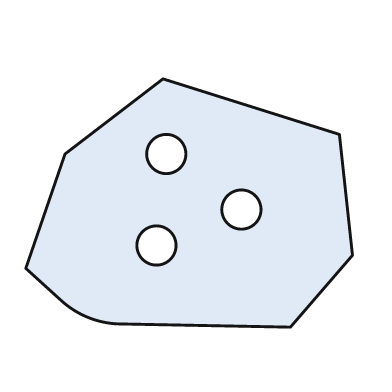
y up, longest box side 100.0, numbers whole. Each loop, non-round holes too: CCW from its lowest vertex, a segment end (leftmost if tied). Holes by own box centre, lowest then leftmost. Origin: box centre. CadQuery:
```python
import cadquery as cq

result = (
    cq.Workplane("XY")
    .moveTo(31.0, -38.0)
    .lineTo(50.0, -16.0)
    .lineTo(46.0, 21.0)
    .lineTo(-8.0, 38.0)
    .lineTo(-38.0, 15.0)
    .lineTo(-50.0, -20.0)
    .lineTo(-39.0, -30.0)
    .threePointArc((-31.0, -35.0), (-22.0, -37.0))
    .close()
    .moveTo(-10.0, -13.0)
    .circle(6.0)
    .moveTo(16.0, -2.0)
    .circle(6.0)
    .moveTo(-7.0, 15.0)
    .circle(6.0)
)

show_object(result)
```